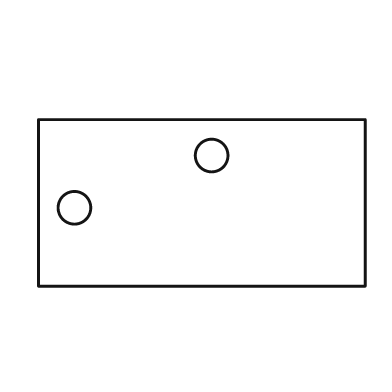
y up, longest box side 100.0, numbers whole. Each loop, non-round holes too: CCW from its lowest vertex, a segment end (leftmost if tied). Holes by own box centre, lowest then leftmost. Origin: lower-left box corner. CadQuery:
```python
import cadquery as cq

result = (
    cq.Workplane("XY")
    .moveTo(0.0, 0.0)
    .lineTo(100.0, 0.0)
    .lineTo(100.0, 51.0)
    .lineTo(0.0, 51.0)
    .close()
    .moveTo(11.0, 24.0)
    .circle(5.0)
    .moveTo(53.0, 40.0)
    .circle(5.0)
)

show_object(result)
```